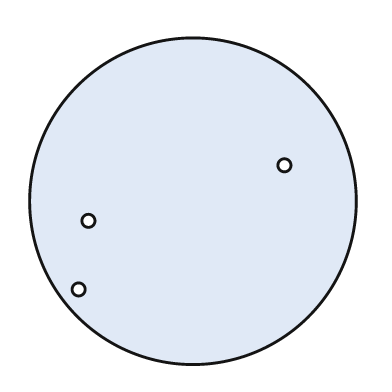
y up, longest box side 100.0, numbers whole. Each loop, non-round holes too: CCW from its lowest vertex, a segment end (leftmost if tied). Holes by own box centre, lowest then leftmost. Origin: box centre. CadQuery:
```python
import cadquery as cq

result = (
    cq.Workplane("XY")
    .moveTo(0.0, 0.0)
    .circle(50.0)
    .moveTo(-35.0, -27.0)
    .circle(2.0)
    .moveTo(-32.0, -6.0)
    .circle(2.0)
    .moveTo(28.0, 11.0)
    .circle(2.0)
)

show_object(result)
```